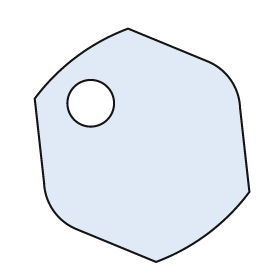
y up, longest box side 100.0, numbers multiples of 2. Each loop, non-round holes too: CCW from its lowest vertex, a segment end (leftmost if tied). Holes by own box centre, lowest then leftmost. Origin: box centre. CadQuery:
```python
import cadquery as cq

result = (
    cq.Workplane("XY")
    .moveTo(6.0, -50.0)
    .threePointArc((28.0, -38.0), (46.0, -20.0))
    .lineTo(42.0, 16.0)
    .threePointArc((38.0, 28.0), (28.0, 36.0))
    .lineTo(-6.0, 50.0)
    .threePointArc((-28.0, 38.0), (-46.0, 20.0))
    .lineTo(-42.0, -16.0)
    .threePointArc((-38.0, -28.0), (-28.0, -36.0))
    .close()
    .moveTo(-22.0, 18.0)
    .circle(10.0)
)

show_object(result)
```